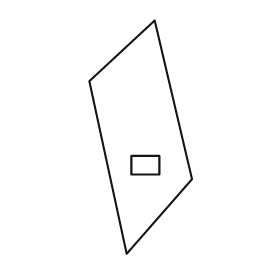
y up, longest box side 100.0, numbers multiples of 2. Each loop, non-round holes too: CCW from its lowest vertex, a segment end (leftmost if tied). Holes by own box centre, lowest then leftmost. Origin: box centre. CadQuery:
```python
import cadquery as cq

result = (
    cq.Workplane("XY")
    .moveTo(-6.0, -50.0)
    .lineTo(22.0, -18.0)
    .lineTo(6.0, 50.0)
    .lineTo(-22.0, 24.0)
    .close()
    .moveTo(-4.0, -16.0)
    .lineTo(8.0, -16.0)
    .lineTo(8.0, -8.0)
    .lineTo(-4.0, -8.0)
    .close()
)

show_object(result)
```